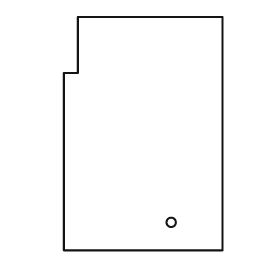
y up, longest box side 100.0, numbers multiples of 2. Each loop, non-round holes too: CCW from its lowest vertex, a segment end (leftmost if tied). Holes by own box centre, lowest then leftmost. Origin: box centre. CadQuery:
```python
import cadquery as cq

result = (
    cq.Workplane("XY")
    .moveTo(-34.0, -50.0)
    .lineTo(34.0, -50.0)
    .lineTo(34.0, 50.0)
    .lineTo(-28.0, 50.0)
    .lineTo(-28.0, 26.0)
    .lineTo(-34.0, 26.0)
    .close()
    .moveTo(12.0, -38.0)
    .circle(2.0)
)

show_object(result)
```